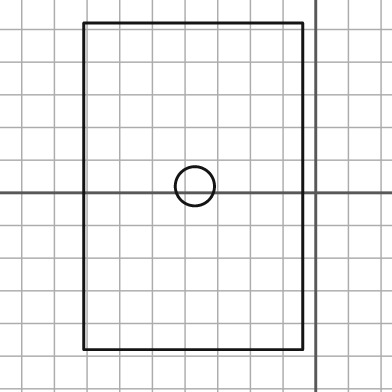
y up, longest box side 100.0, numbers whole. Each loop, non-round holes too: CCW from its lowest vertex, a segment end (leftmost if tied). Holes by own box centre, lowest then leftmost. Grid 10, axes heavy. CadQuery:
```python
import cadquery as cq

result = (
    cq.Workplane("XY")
    .moveTo(-71.0, -48.0)
    .lineTo(-4.0, -48.0)
    .lineTo(-4.0, 52.0)
    .lineTo(-71.0, 52.0)
    .close()
    .moveTo(-37.0, 2.0)
    .circle(6.0)
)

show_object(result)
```